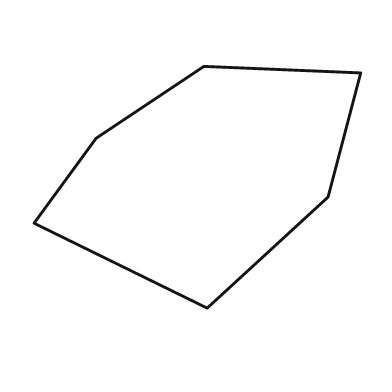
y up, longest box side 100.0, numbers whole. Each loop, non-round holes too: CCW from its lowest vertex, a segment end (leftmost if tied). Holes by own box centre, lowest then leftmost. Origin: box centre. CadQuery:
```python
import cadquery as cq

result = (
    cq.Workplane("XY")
    .moveTo(3.0, -37.0)
    .lineTo(40.0, -3.0)
    .lineTo(50.0, 35.0)
    .lineTo(2.0, 37.0)
    .lineTo(-31.0, 15.0)
    .lineTo(-50.0, -11.0)
    .close()
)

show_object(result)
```